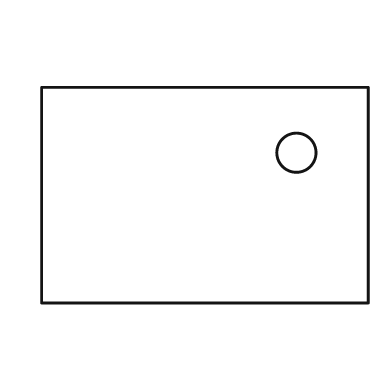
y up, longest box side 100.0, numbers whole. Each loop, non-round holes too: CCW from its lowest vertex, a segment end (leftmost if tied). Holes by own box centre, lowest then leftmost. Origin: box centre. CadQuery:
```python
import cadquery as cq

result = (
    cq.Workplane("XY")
    .moveTo(-50.0, -33.0)
    .lineTo(50.0, -33.0)
    .lineTo(50.0, 33.0)
    .lineTo(-50.0, 33.0)
    .close()
    .moveTo(28.0, 13.0)
    .circle(6.0)
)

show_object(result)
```